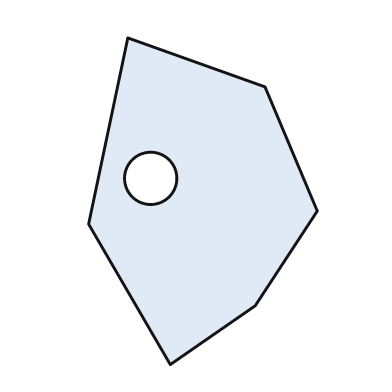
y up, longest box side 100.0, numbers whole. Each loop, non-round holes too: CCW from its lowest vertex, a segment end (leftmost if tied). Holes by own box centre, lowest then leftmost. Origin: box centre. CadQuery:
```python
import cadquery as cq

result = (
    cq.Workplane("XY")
    .moveTo(-10.0, -50.0)
    .lineTo(16.0, -32.0)
    .lineTo(35.0, -3.0)
    .lineTo(19.0, 35.0)
    .lineTo(-23.0, 50.0)
    .lineTo(-35.0, -7.0)
    .close()
    .moveTo(-16.0, 7.0)
    .circle(8.0)
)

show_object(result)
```